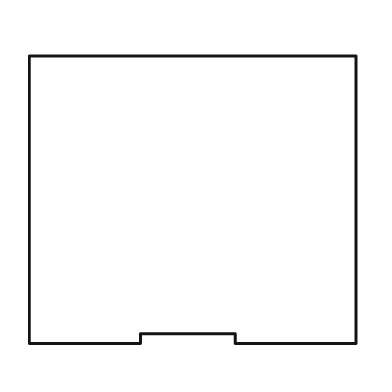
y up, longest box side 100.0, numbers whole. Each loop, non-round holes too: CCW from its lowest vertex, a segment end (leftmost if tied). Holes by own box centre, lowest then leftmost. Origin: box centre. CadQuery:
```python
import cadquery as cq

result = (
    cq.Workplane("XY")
    .moveTo(-50.0, -44.0)
    .lineTo(-16.0, -44.0)
    .lineTo(-16.0, -41.0)
    .lineTo(13.0, -41.0)
    .lineTo(13.0, -44.0)
    .lineTo(50.0, -44.0)
    .lineTo(50.0, 44.0)
    .lineTo(-50.0, 44.0)
    .close()
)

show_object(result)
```